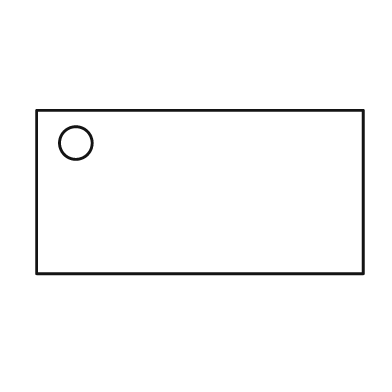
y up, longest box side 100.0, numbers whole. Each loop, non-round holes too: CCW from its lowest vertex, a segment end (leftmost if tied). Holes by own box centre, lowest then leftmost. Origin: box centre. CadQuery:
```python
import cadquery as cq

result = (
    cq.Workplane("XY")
    .moveTo(-50.0, -25.0)
    .lineTo(50.0, -25.0)
    .lineTo(50.0, 25.0)
    .lineTo(-50.0, 25.0)
    .close()
    .moveTo(-38.0, 15.0)
    .circle(5.0)
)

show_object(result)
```